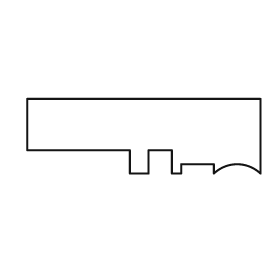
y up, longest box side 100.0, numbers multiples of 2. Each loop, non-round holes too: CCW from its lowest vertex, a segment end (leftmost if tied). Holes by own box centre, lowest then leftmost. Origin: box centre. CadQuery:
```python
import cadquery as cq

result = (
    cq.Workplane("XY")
    .moveTo(-6.0, -16.0)
    .lineTo(2.0, -16.0)
    .lineTo(2.0, -6.0)
    .lineTo(12.0, -6.0)
    .lineTo(12.0, -16.0)
    .lineTo(16.0, -16.0)
    .lineTo(16.0, -12.0)
    .lineTo(30.0, -12.0)
    .lineTo(30.0, -16.0)
    .threePointArc((40.0, -12.0), (50.0, -16.0))
    .lineTo(50.0, 16.0)
    .lineTo(-50.0, 16.0)
    .lineTo(-50.0, -6.0)
    .lineTo(-6.0, -6.0)
    .close()
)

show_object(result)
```